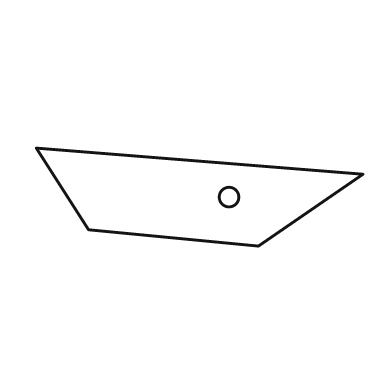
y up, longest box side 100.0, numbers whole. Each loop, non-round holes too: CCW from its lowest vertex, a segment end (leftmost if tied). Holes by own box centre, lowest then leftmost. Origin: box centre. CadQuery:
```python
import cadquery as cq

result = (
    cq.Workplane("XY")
    .moveTo(18.0, -15.0)
    .lineTo(50.0, 7.0)
    .lineTo(-50.0, 15.0)
    .lineTo(-34.0, -10.0)
    .close()
    .moveTo(9.0, 0.0)
    .circle(3.0)
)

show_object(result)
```